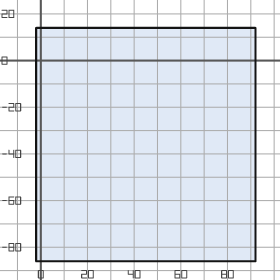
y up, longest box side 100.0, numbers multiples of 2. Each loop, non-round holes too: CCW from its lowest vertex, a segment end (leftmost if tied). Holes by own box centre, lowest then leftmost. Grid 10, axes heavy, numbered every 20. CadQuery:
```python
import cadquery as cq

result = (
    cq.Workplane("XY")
    .moveTo(-2.0, -86.0)
    .lineTo(92.0, -86.0)
    .lineTo(92.0, 14.0)
    .lineTo(-2.0, 14.0)
    .close()
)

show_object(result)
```